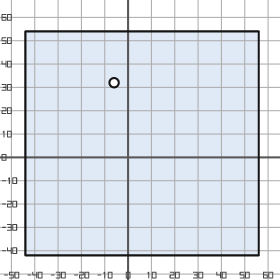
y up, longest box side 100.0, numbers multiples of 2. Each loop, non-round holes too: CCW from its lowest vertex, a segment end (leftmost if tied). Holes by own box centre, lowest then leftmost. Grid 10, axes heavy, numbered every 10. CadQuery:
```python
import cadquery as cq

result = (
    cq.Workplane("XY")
    .moveTo(-44.0, -42.0)
    .lineTo(56.0, -42.0)
    .lineTo(56.0, 54.0)
    .lineTo(-44.0, 54.0)
    .close()
    .moveTo(-6.0, 32.0)
    .circle(2.0)
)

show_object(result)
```